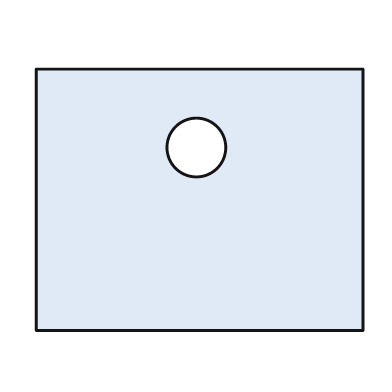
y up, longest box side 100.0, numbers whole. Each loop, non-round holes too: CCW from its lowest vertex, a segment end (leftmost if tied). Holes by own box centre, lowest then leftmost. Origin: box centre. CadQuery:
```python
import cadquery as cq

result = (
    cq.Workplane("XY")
    .moveTo(-50.0, -40.0)
    .lineTo(50.0, -40.0)
    .lineTo(50.0, 40.0)
    .lineTo(-50.0, 40.0)
    .close()
    .moveTo(-1.0, 16.0)
    .circle(9.0)
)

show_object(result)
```